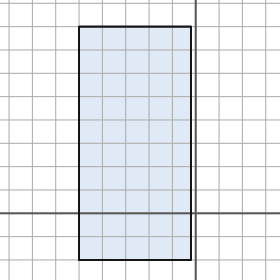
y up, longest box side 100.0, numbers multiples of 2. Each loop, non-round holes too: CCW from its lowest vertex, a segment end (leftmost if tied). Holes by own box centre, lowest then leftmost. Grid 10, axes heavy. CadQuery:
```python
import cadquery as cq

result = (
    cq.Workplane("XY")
    .moveTo(-50.0, -20.0)
    .lineTo(-2.0, -20.0)
    .lineTo(-2.0, 80.0)
    .lineTo(-50.0, 80.0)
    .close()
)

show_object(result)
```